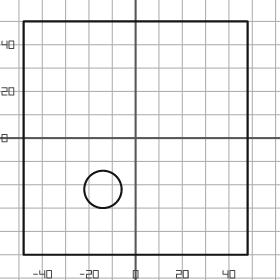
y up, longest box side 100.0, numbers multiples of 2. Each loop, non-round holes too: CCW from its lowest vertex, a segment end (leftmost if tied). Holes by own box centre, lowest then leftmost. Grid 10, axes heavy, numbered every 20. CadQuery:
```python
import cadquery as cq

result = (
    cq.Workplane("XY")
    .moveTo(-48.0, -50.0)
    .lineTo(48.0, -50.0)
    .lineTo(48.0, 50.0)
    .lineTo(-48.0, 50.0)
    .close()
    .moveTo(-14.0, -22.0)
    .circle(8.0)
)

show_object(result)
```